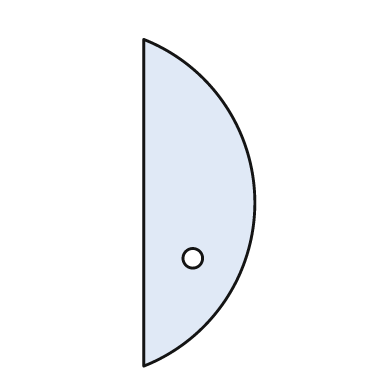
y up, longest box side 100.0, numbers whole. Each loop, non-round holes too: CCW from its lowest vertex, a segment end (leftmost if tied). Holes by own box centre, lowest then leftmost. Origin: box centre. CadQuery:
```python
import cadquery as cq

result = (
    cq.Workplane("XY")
    .moveTo(-17.0, -50.0)
    .threePointArc((17.0, 0.0), (-17.0, 50.0))
    .close()
    .moveTo(-2.0, -17.0)
    .circle(3.0)
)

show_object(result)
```